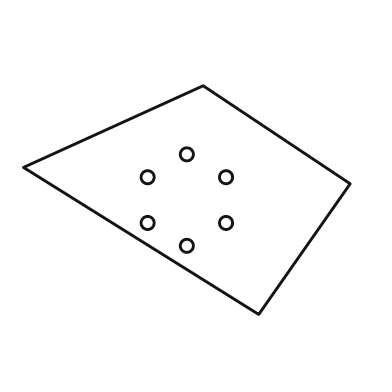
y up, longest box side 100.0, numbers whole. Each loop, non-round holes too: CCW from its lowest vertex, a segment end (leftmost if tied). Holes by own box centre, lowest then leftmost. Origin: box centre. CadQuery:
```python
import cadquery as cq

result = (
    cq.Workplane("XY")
    .moveTo(22.0, -35.0)
    .lineTo(50.0, 5.0)
    .lineTo(5.0, 35.0)
    .lineTo(-50.0, 10.0)
    .close()
    .moveTo(0.0, -14.0)
    .circle(2.0)
    .moveTo(-12.0, -7.0)
    .circle(2.0)
    .moveTo(12.0, -7.0)
    .circle(2.0)
    .moveTo(-12.0, 7.0)
    .circle(2.0)
    .moveTo(12.0, 7.0)
    .circle(2.0)
    .moveTo(0.0, 14.0)
    .circle(2.0)
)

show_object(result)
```